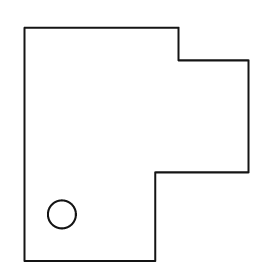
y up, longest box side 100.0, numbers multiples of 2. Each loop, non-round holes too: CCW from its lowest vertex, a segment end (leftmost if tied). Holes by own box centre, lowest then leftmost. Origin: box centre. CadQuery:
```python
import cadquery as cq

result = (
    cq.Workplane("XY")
    .moveTo(-48.0, -50.0)
    .lineTo(8.0, -50.0)
    .lineTo(8.0, -12.0)
    .lineTo(48.0, -12.0)
    .lineTo(48.0, 36.0)
    .lineTo(18.0, 36.0)
    .lineTo(18.0, 50.0)
    .lineTo(-48.0, 50.0)
    .close()
    .moveTo(-32.0, -30.0)
    .circle(6.0)
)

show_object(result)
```